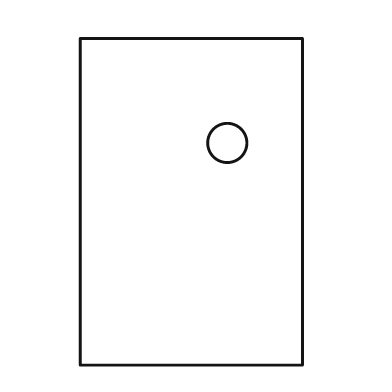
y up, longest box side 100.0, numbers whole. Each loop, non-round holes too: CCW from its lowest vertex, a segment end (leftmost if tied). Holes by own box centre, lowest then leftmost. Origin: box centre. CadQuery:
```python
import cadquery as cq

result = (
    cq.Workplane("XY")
    .moveTo(-34.0, -50.0)
    .lineTo(34.0, -50.0)
    .lineTo(34.0, 50.0)
    .lineTo(-34.0, 50.0)
    .close()
    .moveTo(11.0, 18.0)
    .circle(6.0)
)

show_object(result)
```